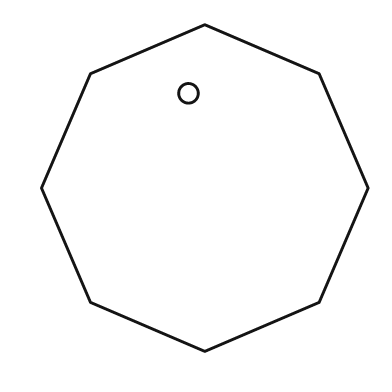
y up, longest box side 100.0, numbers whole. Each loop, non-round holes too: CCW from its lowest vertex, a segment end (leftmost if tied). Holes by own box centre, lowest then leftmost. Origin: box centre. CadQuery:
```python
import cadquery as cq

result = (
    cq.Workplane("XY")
    .moveTo(0.0, -50.0)
    .lineTo(35.0, -35.0)
    .lineTo(50.0, 0.0)
    .lineTo(35.0, 35.0)
    .lineTo(0.0, 50.0)
    .lineTo(-35.0, 35.0)
    .lineTo(-50.0, 0.0)
    .lineTo(-35.0, -35.0)
    .close()
    .moveTo(-5.0, 29.0)
    .circle(3.0)
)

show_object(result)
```